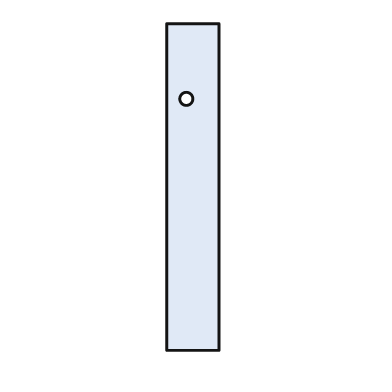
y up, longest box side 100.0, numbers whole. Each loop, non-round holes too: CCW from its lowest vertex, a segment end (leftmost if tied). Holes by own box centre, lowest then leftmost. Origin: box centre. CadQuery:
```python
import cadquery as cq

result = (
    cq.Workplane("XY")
    .moveTo(-8.0, -50.0)
    .lineTo(8.0, -50.0)
    .lineTo(8.0, 50.0)
    .lineTo(-8.0, 50.0)
    .close()
    .moveTo(-2.0, 27.0)
    .circle(2.0)
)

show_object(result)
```